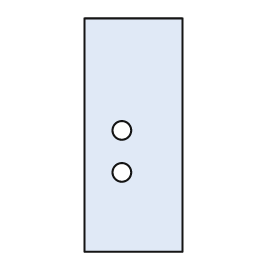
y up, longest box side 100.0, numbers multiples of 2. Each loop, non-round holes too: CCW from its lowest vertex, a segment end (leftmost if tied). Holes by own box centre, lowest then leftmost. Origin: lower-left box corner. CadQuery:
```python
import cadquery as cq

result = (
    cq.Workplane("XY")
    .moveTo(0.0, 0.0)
    .lineTo(42.0, 0.0)
    .lineTo(42.0, 100.0)
    .lineTo(0.0, 100.0)
    .close()
    .moveTo(16.0, 34.0)
    .circle(4.0)
    .moveTo(16.0, 52.0)
    .circle(4.0)
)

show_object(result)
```